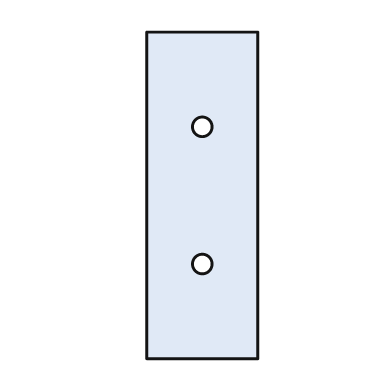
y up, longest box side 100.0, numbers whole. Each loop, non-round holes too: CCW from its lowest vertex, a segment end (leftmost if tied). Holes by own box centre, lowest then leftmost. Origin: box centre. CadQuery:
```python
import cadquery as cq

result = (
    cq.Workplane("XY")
    .moveTo(-17.0, -50.0)
    .lineTo(17.0, -50.0)
    .lineTo(17.0, 50.0)
    .lineTo(-17.0, 50.0)
    .close()
    .moveTo(0.0, -21.0)
    .circle(3.0)
    .moveTo(0.0, 21.0)
    .circle(3.0)
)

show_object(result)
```